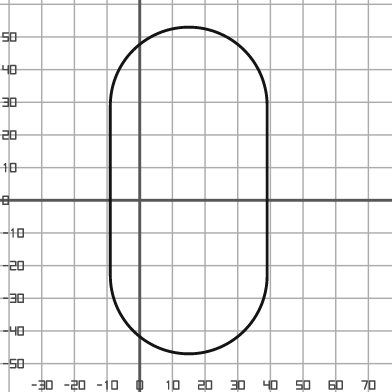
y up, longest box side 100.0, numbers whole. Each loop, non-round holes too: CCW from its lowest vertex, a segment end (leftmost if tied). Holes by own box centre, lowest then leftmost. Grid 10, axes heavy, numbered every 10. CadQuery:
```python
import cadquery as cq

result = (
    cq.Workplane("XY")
    .moveTo(-9.0, -23.0)
    .threePointArc((15.0, -47.0), (39.0, -23.0))
    .lineTo(39.0, 29.0)
    .threePointArc((15.0, 53.0), (-9.0, 29.0))
    .close()
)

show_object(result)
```